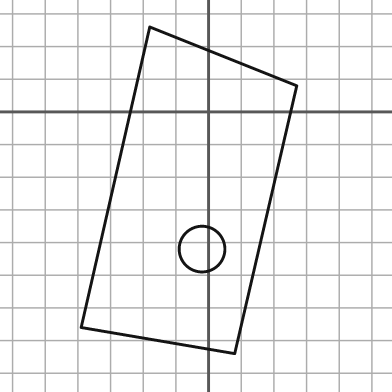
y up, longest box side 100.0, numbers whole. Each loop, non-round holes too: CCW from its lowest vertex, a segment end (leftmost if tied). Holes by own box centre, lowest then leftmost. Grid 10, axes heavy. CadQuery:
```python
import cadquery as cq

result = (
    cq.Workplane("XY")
    .moveTo(8.0, -74.0)
    .lineTo(27.0, 8.0)
    .lineTo(-18.0, 26.0)
    .lineTo(-39.0, -66.0)
    .close()
    .moveTo(-2.0, -42.0)
    .circle(7.0)
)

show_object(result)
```